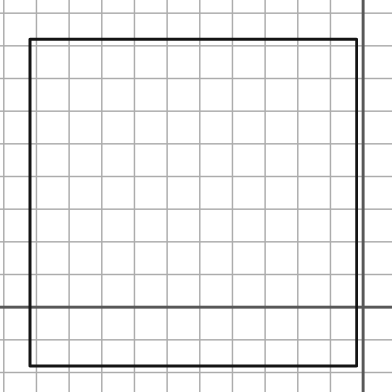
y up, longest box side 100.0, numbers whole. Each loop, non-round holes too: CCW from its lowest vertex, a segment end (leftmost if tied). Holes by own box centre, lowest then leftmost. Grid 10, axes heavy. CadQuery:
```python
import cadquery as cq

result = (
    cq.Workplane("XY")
    .moveTo(-102.0, -18.0)
    .lineTo(-2.0, -18.0)
    .lineTo(-2.0, 82.0)
    .lineTo(-102.0, 82.0)
    .close()
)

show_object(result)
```